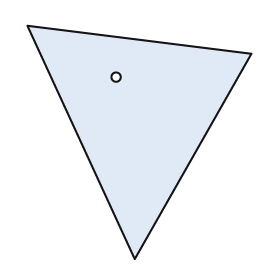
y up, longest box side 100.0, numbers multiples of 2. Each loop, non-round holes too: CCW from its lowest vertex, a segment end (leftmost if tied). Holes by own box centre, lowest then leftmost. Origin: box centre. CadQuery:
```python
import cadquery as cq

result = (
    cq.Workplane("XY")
    .moveTo(-2.0, -50.0)
    .lineTo(48.0, 38.0)
    .lineTo(-48.0, 50.0)
    .close()
    .moveTo(-10.0, 28.0)
    .circle(2.0)
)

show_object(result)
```